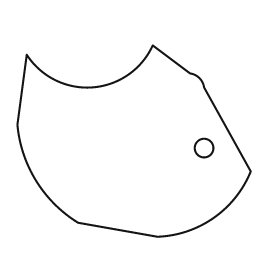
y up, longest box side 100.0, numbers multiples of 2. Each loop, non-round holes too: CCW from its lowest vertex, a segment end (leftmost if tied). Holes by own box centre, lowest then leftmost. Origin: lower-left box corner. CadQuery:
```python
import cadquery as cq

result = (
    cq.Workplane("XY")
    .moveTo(60.0, 0.0)
    .threePointArc((84.0, 8.0), (100.0, 28.0))
    .lineTo(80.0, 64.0)
    .threePointArc((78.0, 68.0), (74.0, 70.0))
    .lineTo(58.0, 82.0)
    .threePointArc((32.0, 64.0), (4.0, 78.0))
    .lineTo(0.0, 48.0)
    .threePointArc((8.0, 24.0), (26.0, 6.0))
    .close()
    .moveTo(80.0, 38.0)
    .circle(4.0)
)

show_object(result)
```